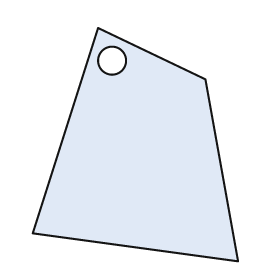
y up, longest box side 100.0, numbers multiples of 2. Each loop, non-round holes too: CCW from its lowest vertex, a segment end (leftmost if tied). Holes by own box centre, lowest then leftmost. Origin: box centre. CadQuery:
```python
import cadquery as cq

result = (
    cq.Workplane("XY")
    .moveTo(44.0, -50.0)
    .lineTo(30.0, 28.0)
    .lineTo(-16.0, 50.0)
    .lineTo(-44.0, -38.0)
    .close()
    .moveTo(-10.0, 36.0)
    .circle(6.0)
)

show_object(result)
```